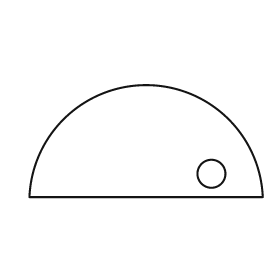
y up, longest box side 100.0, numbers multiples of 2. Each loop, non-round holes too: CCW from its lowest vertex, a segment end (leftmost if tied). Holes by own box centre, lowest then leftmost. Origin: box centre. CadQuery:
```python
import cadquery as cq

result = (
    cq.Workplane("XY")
    .moveTo(-50.0, -24.0)
    .lineTo(50.0, -24.0)
    .threePointArc((0.0, 24.0), (-50.0, -24.0))
    .close()
    .moveTo(28.0, -14.0)
    .circle(6.0)
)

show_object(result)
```